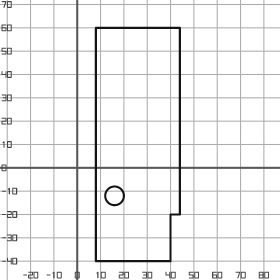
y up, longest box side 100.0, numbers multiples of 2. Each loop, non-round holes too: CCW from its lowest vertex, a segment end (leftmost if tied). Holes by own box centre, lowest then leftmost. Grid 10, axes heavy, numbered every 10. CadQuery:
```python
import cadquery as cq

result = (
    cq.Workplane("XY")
    .moveTo(8.0, -40.0)
    .lineTo(40.0, -40.0)
    .lineTo(40.0, -20.0)
    .lineTo(44.0, -20.0)
    .lineTo(44.0, 60.0)
    .lineTo(8.0, 60.0)
    .close()
    .moveTo(16.0, -12.0)
    .circle(4.0)
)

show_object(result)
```